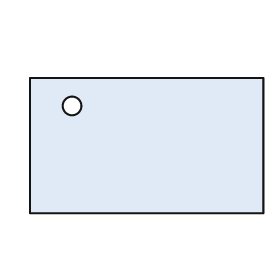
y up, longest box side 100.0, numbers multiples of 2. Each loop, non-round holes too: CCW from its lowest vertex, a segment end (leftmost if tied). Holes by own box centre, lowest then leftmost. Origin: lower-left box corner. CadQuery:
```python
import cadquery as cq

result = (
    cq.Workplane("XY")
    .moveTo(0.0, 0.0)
    .lineTo(100.0, 0.0)
    .lineTo(100.0, 58.0)
    .lineTo(0.0, 58.0)
    .close()
    .moveTo(18.0, 46.0)
    .circle(4.0)
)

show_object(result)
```